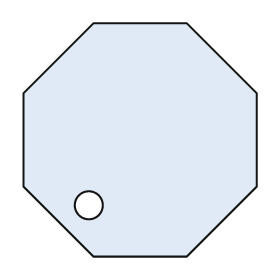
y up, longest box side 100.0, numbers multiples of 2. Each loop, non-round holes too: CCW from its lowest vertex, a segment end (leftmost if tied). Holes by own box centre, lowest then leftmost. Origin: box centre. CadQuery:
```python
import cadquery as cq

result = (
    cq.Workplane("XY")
    .moveTo(-20.0, -50.0)
    .lineTo(20.0, -50.0)
    .lineTo(50.0, -20.0)
    .lineTo(50.0, 20.0)
    .lineTo(20.0, 50.0)
    .lineTo(-20.0, 50.0)
    .lineTo(-50.0, 20.0)
    .lineTo(-50.0, -20.0)
    .close()
    .moveTo(-22.0, -28.0)
    .circle(6.0)
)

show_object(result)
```